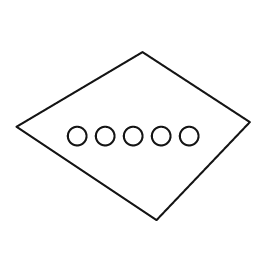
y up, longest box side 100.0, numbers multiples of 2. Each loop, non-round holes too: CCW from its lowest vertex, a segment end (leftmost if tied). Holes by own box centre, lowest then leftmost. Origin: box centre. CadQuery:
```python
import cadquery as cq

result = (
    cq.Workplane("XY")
    .moveTo(10.0, -36.0)
    .lineTo(50.0, 6.0)
    .lineTo(4.0, 36.0)
    .lineTo(-50.0, 4.0)
    .close()
    .moveTo(-24.0, 0.0)
    .circle(4.0)
    .moveTo(-12.0, 0.0)
    .circle(4.0)
    .moveTo(0.0, 0.0)
    .circle(4.0)
    .moveTo(12.0, 0.0)
    .circle(4.0)
    .moveTo(24.0, 0.0)
    .circle(4.0)
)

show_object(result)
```